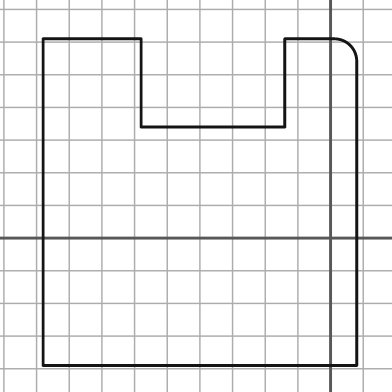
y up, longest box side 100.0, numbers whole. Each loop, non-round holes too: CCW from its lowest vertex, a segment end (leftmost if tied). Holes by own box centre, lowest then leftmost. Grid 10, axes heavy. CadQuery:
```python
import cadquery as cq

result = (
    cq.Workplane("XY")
    .moveTo(-88.0, -39.0)
    .lineTo(8.0, -39.0)
    .lineTo(8.0, 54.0)
    .threePointArc((6.0, 59.0), (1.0, 61.0))
    .lineTo(-14.0, 61.0)
    .lineTo(-14.0, 34.0)
    .lineTo(-58.0, 34.0)
    .lineTo(-58.0, 61.0)
    .lineTo(-88.0, 61.0)
    .close()
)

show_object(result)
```